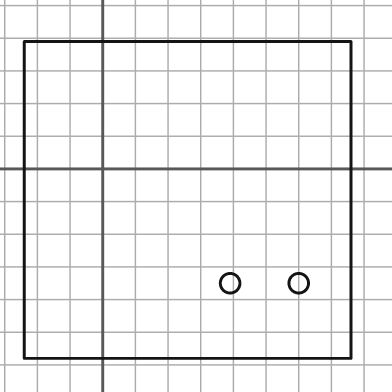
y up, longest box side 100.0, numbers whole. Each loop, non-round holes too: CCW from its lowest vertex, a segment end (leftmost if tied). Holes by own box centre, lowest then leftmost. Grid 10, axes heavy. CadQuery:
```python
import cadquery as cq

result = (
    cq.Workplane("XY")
    .moveTo(-24.0, -58.0)
    .lineTo(76.0, -58.0)
    .lineTo(76.0, 39.0)
    .lineTo(-24.0, 39.0)
    .close()
    .moveTo(39.0, -35.0)
    .circle(3.0)
    .moveTo(60.0, -35.0)
    .circle(3.0)
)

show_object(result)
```